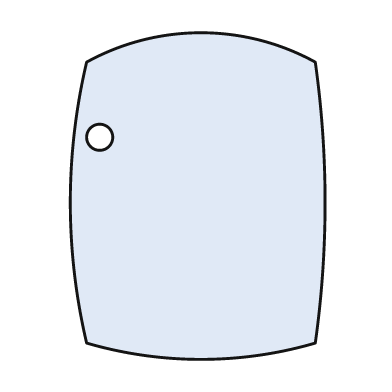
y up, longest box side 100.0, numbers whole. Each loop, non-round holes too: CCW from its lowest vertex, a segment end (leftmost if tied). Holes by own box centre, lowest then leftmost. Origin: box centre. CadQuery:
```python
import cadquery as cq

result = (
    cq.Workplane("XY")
    .moveTo(-34.0, -45.0)
    .threePointArc((1.0, -50.0), (36.0, -45.0))
    .threePointArc((39.0, -2.0), (36.0, 41.0))
    .threePointArc((1.0, 50.0), (-34.0, 41.0))
    .threePointArc((-39.0, -2.0), (-34.0, -45.0))
    .close()
    .moveTo(-30.0, 18.0)
    .circle(4.0)
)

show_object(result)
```